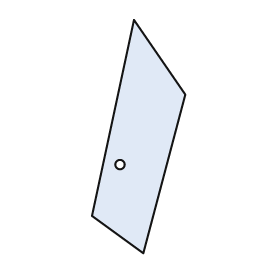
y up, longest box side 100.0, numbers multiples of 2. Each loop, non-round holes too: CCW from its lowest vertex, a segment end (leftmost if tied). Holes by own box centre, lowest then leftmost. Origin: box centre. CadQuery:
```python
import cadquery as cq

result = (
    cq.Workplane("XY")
    .moveTo(2.0, -50.0)
    .lineTo(20.0, 18.0)
    .lineTo(-2.0, 50.0)
    .lineTo(-20.0, -34.0)
    .close()
    .moveTo(-8.0, -12.0)
    .circle(2.0)
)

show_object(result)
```